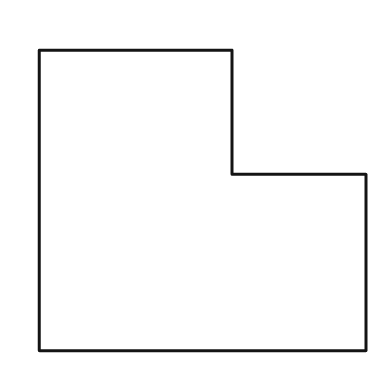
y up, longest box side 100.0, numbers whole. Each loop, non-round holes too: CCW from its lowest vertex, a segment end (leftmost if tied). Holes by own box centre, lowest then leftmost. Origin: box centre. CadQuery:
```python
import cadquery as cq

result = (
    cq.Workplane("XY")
    .moveTo(-50.0, -46.0)
    .lineTo(50.0, -46.0)
    .lineTo(50.0, 8.0)
    .lineTo(9.0, 8.0)
    .lineTo(9.0, 46.0)
    .lineTo(-50.0, 46.0)
    .close()
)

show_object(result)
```